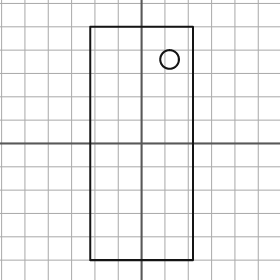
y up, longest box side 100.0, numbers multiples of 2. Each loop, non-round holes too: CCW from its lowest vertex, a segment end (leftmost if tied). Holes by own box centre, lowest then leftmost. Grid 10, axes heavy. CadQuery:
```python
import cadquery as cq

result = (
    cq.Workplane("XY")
    .moveTo(-22.0, -50.0)
    .lineTo(22.0, -50.0)
    .lineTo(22.0, 50.0)
    .lineTo(-22.0, 50.0)
    .close()
    .moveTo(12.0, 36.0)
    .circle(4.0)
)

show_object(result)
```